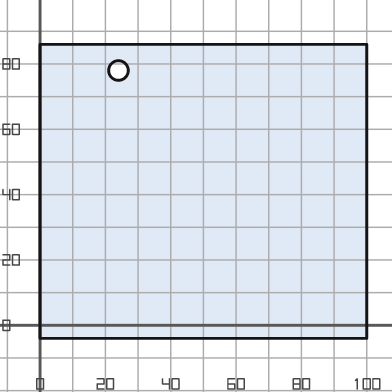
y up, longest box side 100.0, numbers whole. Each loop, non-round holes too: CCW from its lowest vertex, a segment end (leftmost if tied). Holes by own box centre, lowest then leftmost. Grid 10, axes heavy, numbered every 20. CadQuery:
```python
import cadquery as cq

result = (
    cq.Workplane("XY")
    .moveTo(0.0, -4.0)
    .lineTo(100.0, -4.0)
    .lineTo(100.0, 86.0)
    .lineTo(0.0, 86.0)
    .close()
    .moveTo(24.0, 78.0)
    .circle(3.0)
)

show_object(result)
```